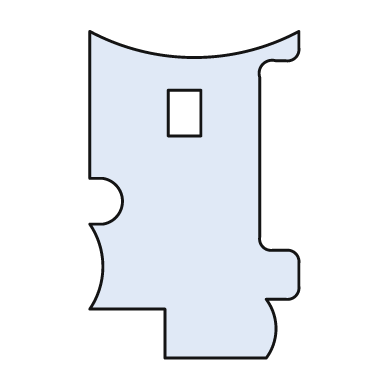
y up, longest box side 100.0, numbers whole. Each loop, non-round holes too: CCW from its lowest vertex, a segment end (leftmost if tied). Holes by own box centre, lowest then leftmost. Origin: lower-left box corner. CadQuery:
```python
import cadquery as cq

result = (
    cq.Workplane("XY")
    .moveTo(23.0, 0.0)
    .lineTo(54.0, 0.0)
    .threePointArc((57.0, 9.0), (54.0, 18.0))
    .lineTo(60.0, 18.0)
    .threePointArc((63.0, 19.0), (64.0, 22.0))
    .lineTo(64.0, 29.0)
    .threePointArc((63.0, 32.0), (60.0, 33.0))
    .lineTo(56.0, 33.0)
    .threePointArc((53.0, 34.0), (52.0, 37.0))
    .lineTo(52.0, 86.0)
    .threePointArc((53.0, 90.0), (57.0, 91.0))
    .lineTo(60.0, 91.0)
    .threePointArc((63.0, 92.0), (64.0, 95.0))
    .lineTo(64.0, 100.0)
    .threePointArc((32.0, 92.0), (0.0, 100.0))
    .lineTo(0.0, 55.0)
    .lineTo(4.0, 55.0)
    .threePointArc((10.0, 48.0), (4.0, 41.0))
    .lineTo(0.0, 41.0)
    .threePointArc((4.0, 28.0), (0.0, 15.0))
    .lineTo(23.0, 15.0)
    .close()
    .moveTo(24.0, 68.0)
    .lineTo(34.0, 68.0)
    .lineTo(34.0, 82.0)
    .lineTo(24.0, 82.0)
    .close()
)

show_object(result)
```